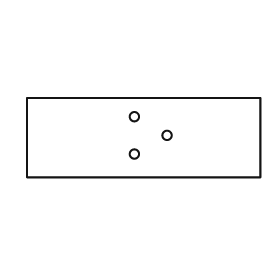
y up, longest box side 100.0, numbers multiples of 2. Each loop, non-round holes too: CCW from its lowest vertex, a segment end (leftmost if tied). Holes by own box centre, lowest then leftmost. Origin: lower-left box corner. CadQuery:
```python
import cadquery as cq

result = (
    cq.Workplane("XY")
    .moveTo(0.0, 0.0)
    .lineTo(100.0, 0.0)
    .lineTo(100.0, 34.0)
    .lineTo(0.0, 34.0)
    .close()
    .moveTo(46.0, 10.0)
    .circle(2.0)
    .moveTo(60.0, 18.0)
    .circle(2.0)
    .moveTo(46.0, 26.0)
    .circle(2.0)
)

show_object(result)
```